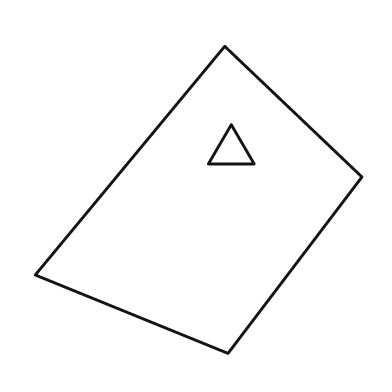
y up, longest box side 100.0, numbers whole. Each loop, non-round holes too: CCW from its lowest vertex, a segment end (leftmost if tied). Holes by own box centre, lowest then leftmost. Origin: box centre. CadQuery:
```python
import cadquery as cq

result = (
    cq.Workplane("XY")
    .moveTo(9.0, -47.0)
    .lineTo(50.0, 7.0)
    .lineTo(8.0, 47.0)
    .lineTo(-50.0, -23.0)
    .close()
    .moveTo(3.0, 11.0)
    .lineTo(17.0, 11.0)
    .lineTo(10.0, 23.0)
    .close()
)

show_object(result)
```